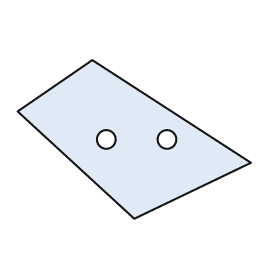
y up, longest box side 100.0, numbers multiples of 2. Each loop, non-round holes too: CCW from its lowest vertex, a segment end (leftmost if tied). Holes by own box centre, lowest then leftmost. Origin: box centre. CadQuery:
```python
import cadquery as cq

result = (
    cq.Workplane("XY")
    .moveTo(0.0, -34.0)
    .lineTo(50.0, -10.0)
    .lineTo(-18.0, 34.0)
    .lineTo(-50.0, 12.0)
    .close()
    .moveTo(-12.0, 0.0)
    .circle(4.0)
    .moveTo(14.0, 0.0)
    .circle(4.0)
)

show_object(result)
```